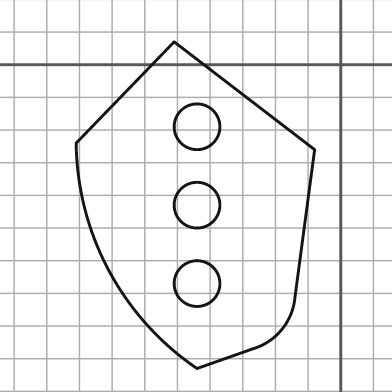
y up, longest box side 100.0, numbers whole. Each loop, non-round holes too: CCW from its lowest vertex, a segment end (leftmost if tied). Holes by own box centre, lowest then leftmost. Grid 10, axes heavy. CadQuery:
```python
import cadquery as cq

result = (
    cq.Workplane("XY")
    .moveTo(-44.0, -93.0)
    .lineTo(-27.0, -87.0)
    .threePointArc((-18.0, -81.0), (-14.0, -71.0))
    .lineTo(-8.0, -26.0)
    .lineTo(-51.0, 7.0)
    .lineTo(-81.0, -24.0)
    .threePointArc((-71.0, -63.0), (-44.0, -93.0))
    .close()
    .moveTo(-44.0, -67.0)
    .circle(7.0)
    .moveTo(-44.0, -43.0)
    .circle(7.0)
    .moveTo(-44.0, -19.0)
    .circle(7.0)
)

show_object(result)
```